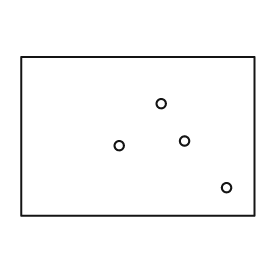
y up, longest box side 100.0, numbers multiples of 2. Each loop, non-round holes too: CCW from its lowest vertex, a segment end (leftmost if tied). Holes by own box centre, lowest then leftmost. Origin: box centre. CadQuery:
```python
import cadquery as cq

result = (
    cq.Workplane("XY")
    .moveTo(-50.0, -34.0)
    .lineTo(50.0, -34.0)
    .lineTo(50.0, 34.0)
    .lineTo(-50.0, 34.0)
    .close()
    .moveTo(38.0, -22.0)
    .circle(2.0)
    .moveTo(-8.0, -4.0)
    .circle(2.0)
    .moveTo(20.0, -2.0)
    .circle(2.0)
    .moveTo(10.0, 14.0)
    .circle(2.0)
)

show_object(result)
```